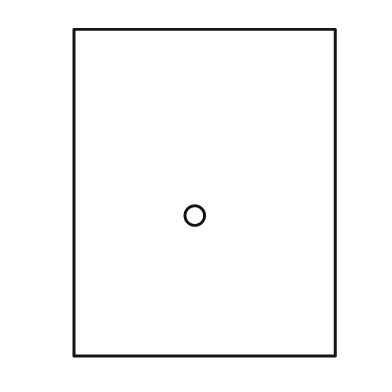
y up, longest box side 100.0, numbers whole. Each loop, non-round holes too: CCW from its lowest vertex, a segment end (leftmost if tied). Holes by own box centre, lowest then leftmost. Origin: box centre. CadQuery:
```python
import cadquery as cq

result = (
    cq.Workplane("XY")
    .moveTo(-40.0, -50.0)
    .lineTo(40.0, -50.0)
    .lineTo(40.0, 50.0)
    .lineTo(-40.0, 50.0)
    .close()
    .moveTo(-3.0, -7.0)
    .circle(3.0)
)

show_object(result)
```